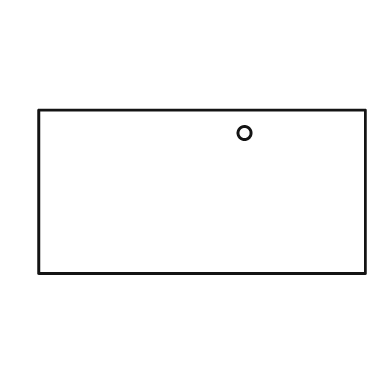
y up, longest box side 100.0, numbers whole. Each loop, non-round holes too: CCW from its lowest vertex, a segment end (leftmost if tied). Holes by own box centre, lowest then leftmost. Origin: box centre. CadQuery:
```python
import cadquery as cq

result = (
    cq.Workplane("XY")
    .moveTo(-50.0, -25.0)
    .lineTo(50.0, -25.0)
    .lineTo(50.0, 25.0)
    .lineTo(-50.0, 25.0)
    .close()
    .moveTo(13.0, 18.0)
    .circle(2.0)
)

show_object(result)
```